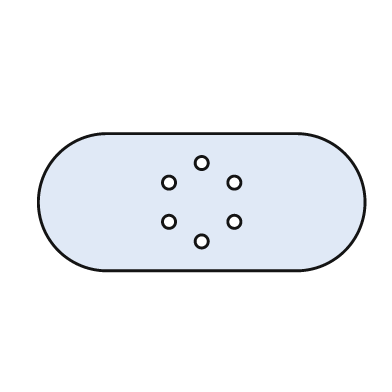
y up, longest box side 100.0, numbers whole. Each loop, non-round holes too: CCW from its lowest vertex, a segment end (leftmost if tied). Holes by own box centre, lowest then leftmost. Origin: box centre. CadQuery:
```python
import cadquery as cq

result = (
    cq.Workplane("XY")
    .moveTo(-29.0, -21.0)
    .lineTo(29.0, -21.0)
    .threePointArc((50.0, 0.0), (29.0, 21.0))
    .lineTo(-29.0, 21.0)
    .threePointArc((-50.0, 0.0), (-29.0, -21.0))
    .close()
    .moveTo(0.0, -12.0)
    .circle(2.0)
    .moveTo(-10.0, -6.0)
    .circle(2.0)
    .moveTo(10.0, -6.0)
    .circle(2.0)
    .moveTo(-10.0, 6.0)
    .circle(2.0)
    .moveTo(10.0, 6.0)
    .circle(2.0)
    .moveTo(0.0, 12.0)
    .circle(2.0)
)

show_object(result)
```